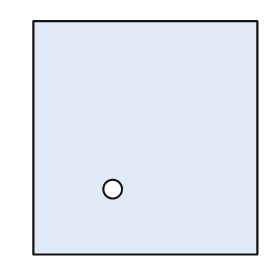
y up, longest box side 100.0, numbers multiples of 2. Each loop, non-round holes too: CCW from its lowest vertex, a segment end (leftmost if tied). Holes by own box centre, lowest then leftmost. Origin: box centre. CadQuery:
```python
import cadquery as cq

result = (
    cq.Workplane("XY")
    .moveTo(-48.0, -50.0)
    .lineTo(48.0, -50.0)
    .lineTo(48.0, 50.0)
    .lineTo(-48.0, 50.0)
    .close()
    .moveTo(-14.0, -22.0)
    .circle(4.0)
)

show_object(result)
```